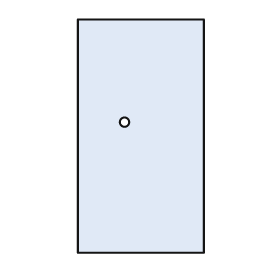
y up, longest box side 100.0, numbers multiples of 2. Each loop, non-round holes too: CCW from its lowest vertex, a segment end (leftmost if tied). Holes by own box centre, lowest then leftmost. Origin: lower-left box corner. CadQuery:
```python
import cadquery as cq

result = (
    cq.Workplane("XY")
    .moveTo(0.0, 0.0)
    .lineTo(54.0, 0.0)
    .lineTo(54.0, 100.0)
    .lineTo(0.0, 100.0)
    .close()
    .moveTo(20.0, 56.0)
    .circle(2.0)
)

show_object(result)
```